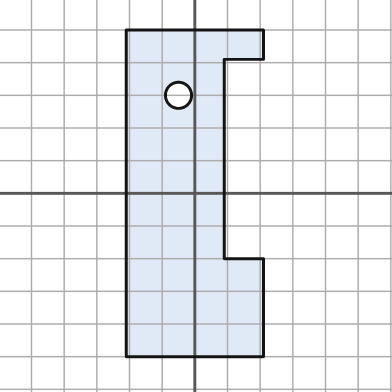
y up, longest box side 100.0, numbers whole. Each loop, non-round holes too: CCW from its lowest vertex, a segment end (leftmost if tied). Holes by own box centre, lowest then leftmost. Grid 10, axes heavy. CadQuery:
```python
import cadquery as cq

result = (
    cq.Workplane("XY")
    .moveTo(-21.0, -50.0)
    .lineTo(21.0, -50.0)
    .lineTo(21.0, -20.0)
    .lineTo(9.0, -20.0)
    .lineTo(9.0, 41.0)
    .lineTo(21.0, 41.0)
    .lineTo(21.0, 50.0)
    .lineTo(-21.0, 50.0)
    .close()
    .moveTo(-5.0, 30.0)
    .circle(4.0)
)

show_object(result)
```